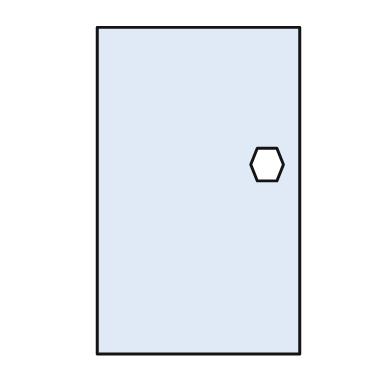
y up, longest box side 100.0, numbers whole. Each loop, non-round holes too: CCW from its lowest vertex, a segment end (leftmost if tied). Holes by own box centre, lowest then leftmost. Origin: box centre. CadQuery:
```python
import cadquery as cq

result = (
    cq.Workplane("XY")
    .moveTo(-31.0, -50.0)
    .lineTo(31.0, -50.0)
    .lineTo(31.0, 50.0)
    .lineTo(-31.0, 50.0)
    .close()
    .moveTo(18.0, 3.0)
    .lineTo(24.0, 3.0)
    .lineTo(26.0, 8.0)
    .lineTo(24.0, 13.0)
    .lineTo(18.0, 13.0)
    .lineTo(16.0, 8.0)
    .close()
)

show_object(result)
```